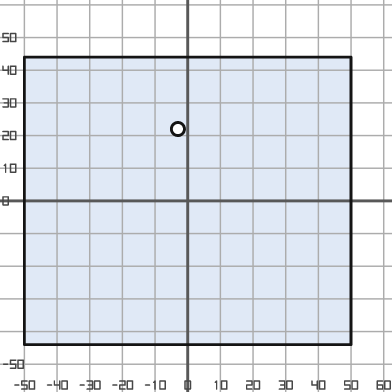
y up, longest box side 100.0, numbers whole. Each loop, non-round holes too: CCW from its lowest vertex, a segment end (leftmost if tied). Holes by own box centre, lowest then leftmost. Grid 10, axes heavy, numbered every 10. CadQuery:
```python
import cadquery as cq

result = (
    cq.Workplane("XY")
    .moveTo(-50.0, -44.0)
    .lineTo(50.0, -44.0)
    .lineTo(50.0, 44.0)
    .lineTo(-50.0, 44.0)
    .close()
    .moveTo(-3.0, 22.0)
    .circle(2.0)
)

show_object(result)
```